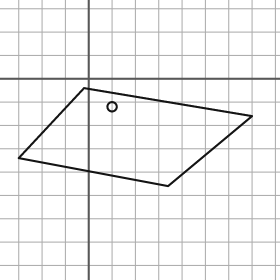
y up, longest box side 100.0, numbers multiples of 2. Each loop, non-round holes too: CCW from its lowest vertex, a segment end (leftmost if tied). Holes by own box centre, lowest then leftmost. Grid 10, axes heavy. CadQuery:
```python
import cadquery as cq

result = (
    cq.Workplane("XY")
    .moveTo(34.0, -46.0)
    .lineTo(70.0, -16.0)
    .lineTo(-2.0, -4.0)
    .lineTo(-30.0, -34.0)
    .close()
    .moveTo(10.0, -12.0)
    .circle(2.0)
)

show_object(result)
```